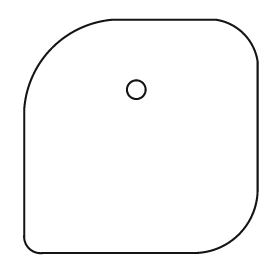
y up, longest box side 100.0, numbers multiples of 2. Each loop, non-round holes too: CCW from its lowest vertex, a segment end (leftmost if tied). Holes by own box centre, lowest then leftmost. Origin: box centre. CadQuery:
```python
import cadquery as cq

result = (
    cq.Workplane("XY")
    .moveTo(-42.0, -50.0)
    .lineTo(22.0, -50.0)
    .threePointArc((42.0, -42.0), (50.0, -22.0))
    .lineTo(50.0, 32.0)
    .threePointArc((44.0, 44.0), (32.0, 50.0))
    .lineTo(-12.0, 50.0)
    .threePointArc((-38.0, 38.0), (-50.0, 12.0))
    .lineTo(-50.0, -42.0)
    .threePointArc((-48.0, -48.0), (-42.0, -50.0))
    .close()
    .moveTo(-2.0, 20.0)
    .circle(4.0)
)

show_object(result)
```